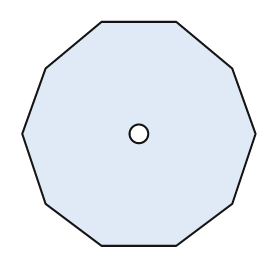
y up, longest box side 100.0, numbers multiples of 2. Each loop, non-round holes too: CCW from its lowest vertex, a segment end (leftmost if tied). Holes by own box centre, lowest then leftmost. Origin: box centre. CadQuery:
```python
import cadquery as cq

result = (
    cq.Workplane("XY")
    .moveTo(-16.0, -48.0)
    .lineTo(16.0, -48.0)
    .lineTo(40.0, -30.0)
    .lineTo(50.0, 0.0)
    .lineTo(40.0, 28.0)
    .lineTo(16.0, 48.0)
    .lineTo(-16.0, 48.0)
    .lineTo(-40.0, 28.0)
    .lineTo(-50.0, 0.0)
    .lineTo(-40.0, -30.0)
    .close()
    .moveTo(0.0, 0.0)
    .circle(4.0)
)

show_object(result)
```